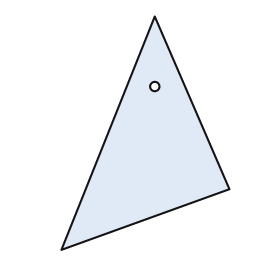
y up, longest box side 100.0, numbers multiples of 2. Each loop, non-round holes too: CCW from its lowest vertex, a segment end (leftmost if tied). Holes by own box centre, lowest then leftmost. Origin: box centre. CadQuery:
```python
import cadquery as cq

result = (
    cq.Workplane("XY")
    .moveTo(-36.0, -50.0)
    .lineTo(36.0, -24.0)
    .lineTo(4.0, 50.0)
    .close()
    .moveTo(4.0, 20.0)
    .circle(2.0)
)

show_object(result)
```